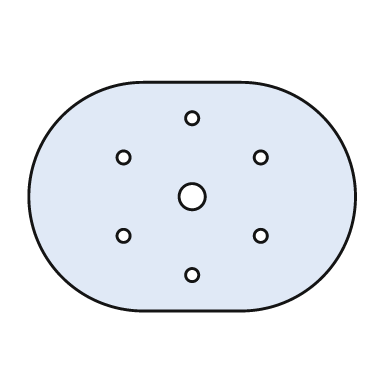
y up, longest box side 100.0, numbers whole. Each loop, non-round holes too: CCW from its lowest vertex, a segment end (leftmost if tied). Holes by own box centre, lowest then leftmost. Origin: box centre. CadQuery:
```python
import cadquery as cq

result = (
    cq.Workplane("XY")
    .moveTo(-15.0, -35.0)
    .lineTo(15.0, -35.0)
    .threePointArc((50.0, 0.0), (15.0, 35.0))
    .lineTo(-15.0, 35.0)
    .threePointArc((-50.0, 0.0), (-15.0, -35.0))
    .close()
    .moveTo(0.0, -24.0)
    .circle(2.0)
    .moveTo(-21.0, -12.0)
    .circle(2.0)
    .moveTo(21.0, -12.0)
    .circle(2.0)
    .moveTo(0.0, 0.0)
    .circle(4.0)
    .moveTo(-21.0, 12.0)
    .circle(2.0)
    .moveTo(21.0, 12.0)
    .circle(2.0)
    .moveTo(0.0, 24.0)
    .circle(2.0)
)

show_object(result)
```